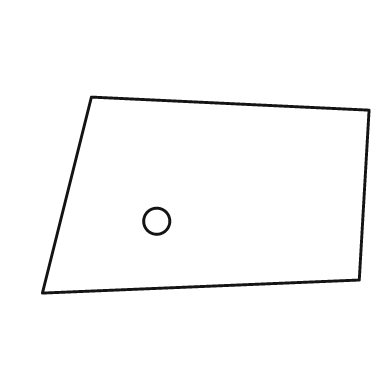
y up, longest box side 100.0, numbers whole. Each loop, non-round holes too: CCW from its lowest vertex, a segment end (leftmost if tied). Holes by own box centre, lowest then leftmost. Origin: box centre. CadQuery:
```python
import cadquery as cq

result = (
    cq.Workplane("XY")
    .moveTo(-50.0, -30.0)
    .lineTo(47.0, -26.0)
    .lineTo(50.0, 26.0)
    .lineTo(-35.0, 30.0)
    .close()
    .moveTo(-15.0, -8.0)
    .circle(4.0)
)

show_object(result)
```